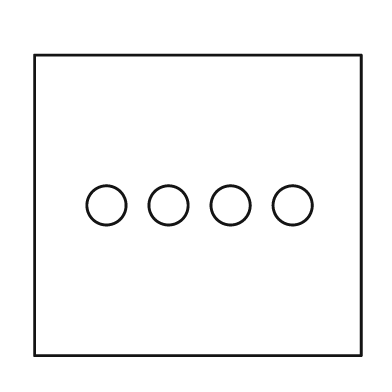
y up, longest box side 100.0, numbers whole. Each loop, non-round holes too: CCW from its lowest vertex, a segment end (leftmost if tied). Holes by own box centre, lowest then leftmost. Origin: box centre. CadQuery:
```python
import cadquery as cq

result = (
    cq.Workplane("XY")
    .moveTo(-50.0, -46.0)
    .lineTo(50.0, -46.0)
    .lineTo(50.0, 46.0)
    .lineTo(-50.0, 46.0)
    .close()
    .moveTo(-28.0, 0.0)
    .circle(6.0)
    .moveTo(-9.0, 0.0)
    .circle(6.0)
    .moveTo(10.0, 0.0)
    .circle(6.0)
    .moveTo(29.0, 0.0)
    .circle(6.0)
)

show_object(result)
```